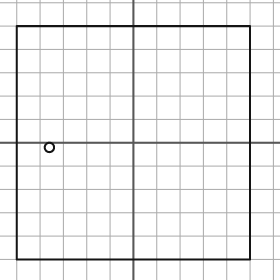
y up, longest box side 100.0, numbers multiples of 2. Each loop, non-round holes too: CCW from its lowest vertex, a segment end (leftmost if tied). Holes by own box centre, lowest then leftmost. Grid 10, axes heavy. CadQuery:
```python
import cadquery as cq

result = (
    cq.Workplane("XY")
    .moveTo(-50.0, -50.0)
    .lineTo(50.0, -50.0)
    .lineTo(50.0, 50.0)
    .lineTo(-50.0, 50.0)
    .close()
    .moveTo(-36.0, -2.0)
    .circle(2.0)
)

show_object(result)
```